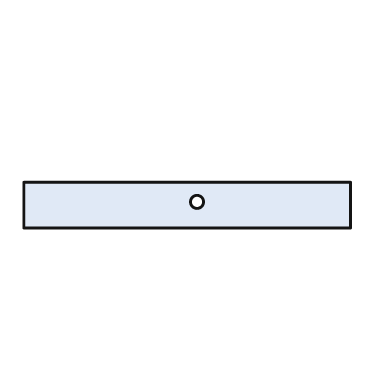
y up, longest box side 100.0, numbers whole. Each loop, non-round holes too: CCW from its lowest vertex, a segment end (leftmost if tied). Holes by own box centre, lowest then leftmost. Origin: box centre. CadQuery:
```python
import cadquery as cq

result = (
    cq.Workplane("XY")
    .moveTo(-50.0, -7.0)
    .lineTo(50.0, -7.0)
    .lineTo(50.0, 7.0)
    .lineTo(-50.0, 7.0)
    .close()
    .moveTo(3.0, 1.0)
    .circle(2.0)
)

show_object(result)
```